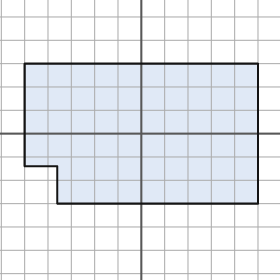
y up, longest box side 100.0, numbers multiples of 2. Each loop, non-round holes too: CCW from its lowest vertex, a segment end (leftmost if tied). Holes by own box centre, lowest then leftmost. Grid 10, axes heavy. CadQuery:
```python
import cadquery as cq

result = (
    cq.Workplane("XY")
    .moveTo(-36.0, -30.0)
    .lineTo(50.0, -30.0)
    .lineTo(50.0, 30.0)
    .lineTo(-50.0, 30.0)
    .lineTo(-50.0, -14.0)
    .lineTo(-36.0, -14.0)
    .close()
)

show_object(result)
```